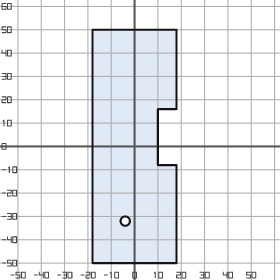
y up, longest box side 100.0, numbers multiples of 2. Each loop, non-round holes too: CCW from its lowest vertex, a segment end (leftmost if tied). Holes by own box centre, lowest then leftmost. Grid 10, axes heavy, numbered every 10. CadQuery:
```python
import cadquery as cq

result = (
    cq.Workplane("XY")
    .moveTo(-18.0, -50.0)
    .lineTo(18.0, -50.0)
    .lineTo(18.0, -8.0)
    .lineTo(10.0, -8.0)
    .lineTo(10.0, 16.0)
    .lineTo(18.0, 16.0)
    .lineTo(18.0, 50.0)
    .lineTo(-18.0, 50.0)
    .close()
    .moveTo(-4.0, -32.0)
    .circle(2.0)
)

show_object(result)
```